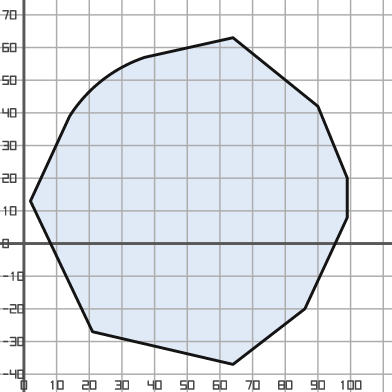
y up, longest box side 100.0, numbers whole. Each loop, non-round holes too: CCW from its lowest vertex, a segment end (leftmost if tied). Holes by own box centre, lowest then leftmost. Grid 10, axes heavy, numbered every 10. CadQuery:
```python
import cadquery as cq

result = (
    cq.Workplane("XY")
    .moveTo(64.0, -37.0)
    .lineTo(86.0, -20.0)
    .lineTo(99.0, 8.0)
    .lineTo(99.0, 20.0)
    .lineTo(90.0, 42.0)
    .lineTo(64.0, 63.0)
    .lineTo(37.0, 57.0)
    .threePointArc((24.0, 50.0), (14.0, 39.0))
    .lineTo(2.0, 13.0)
    .lineTo(21.0, -27.0)
    .close()
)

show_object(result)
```